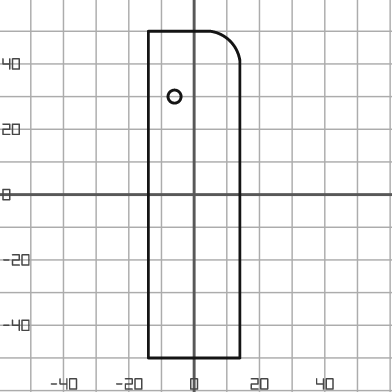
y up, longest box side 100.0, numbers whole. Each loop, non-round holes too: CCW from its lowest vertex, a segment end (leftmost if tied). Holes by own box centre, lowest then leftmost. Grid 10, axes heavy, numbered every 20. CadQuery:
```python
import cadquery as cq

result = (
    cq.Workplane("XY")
    .moveTo(-14.0, -50.0)
    .lineTo(14.0, -50.0)
    .lineTo(14.0, 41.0)
    .threePointArc((11.0, 47.0), (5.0, 50.0))
    .lineTo(-14.0, 50.0)
    .close()
    .moveTo(-6.0, 30.0)
    .circle(2.0)
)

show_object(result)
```